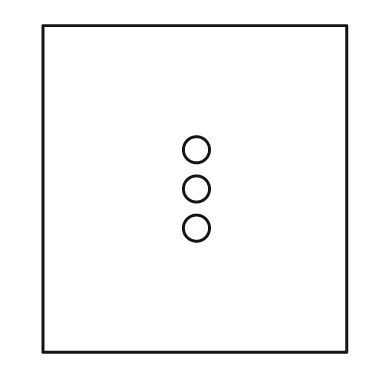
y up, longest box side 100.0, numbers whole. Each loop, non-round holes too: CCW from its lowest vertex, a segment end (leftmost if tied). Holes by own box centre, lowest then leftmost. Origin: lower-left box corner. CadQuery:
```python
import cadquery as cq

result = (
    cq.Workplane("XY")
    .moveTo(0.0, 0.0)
    .lineTo(93.0, 0.0)
    .lineTo(93.0, 100.0)
    .lineTo(0.0, 100.0)
    .close()
    .moveTo(47.0, 38.0)
    .circle(4.0)
    .moveTo(47.0, 50.0)
    .circle(4.0)
    .moveTo(47.0, 62.0)
    .circle(4.0)
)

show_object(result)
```